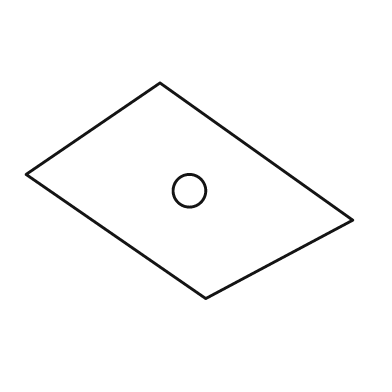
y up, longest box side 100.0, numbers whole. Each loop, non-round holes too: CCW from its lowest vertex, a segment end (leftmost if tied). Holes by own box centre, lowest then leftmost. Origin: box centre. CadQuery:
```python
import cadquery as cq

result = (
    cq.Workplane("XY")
    .moveTo(5.0, -33.0)
    .lineTo(50.0, -9.0)
    .lineTo(-9.0, 33.0)
    .lineTo(-50.0, 5.0)
    .close()
    .moveTo(0.0, 0.0)
    .circle(5.0)
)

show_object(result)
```